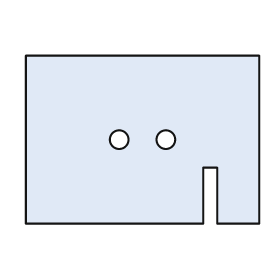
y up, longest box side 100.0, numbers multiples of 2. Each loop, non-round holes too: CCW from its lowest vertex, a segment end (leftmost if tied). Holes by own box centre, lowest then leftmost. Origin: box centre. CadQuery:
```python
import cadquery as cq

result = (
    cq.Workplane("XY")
    .moveTo(-50.0, -36.0)
    .lineTo(26.0, -36.0)
    .lineTo(26.0, -12.0)
    .lineTo(32.0, -12.0)
    .lineTo(32.0, -36.0)
    .lineTo(50.0, -36.0)
    .lineTo(50.0, 36.0)
    .lineTo(-50.0, 36.0)
    .close()
    .moveTo(-10.0, 0.0)
    .circle(4.0)
    .moveTo(10.0, 0.0)
    .circle(4.0)
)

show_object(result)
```